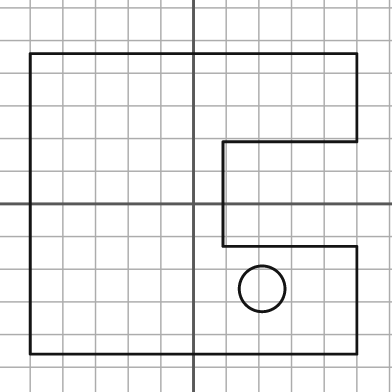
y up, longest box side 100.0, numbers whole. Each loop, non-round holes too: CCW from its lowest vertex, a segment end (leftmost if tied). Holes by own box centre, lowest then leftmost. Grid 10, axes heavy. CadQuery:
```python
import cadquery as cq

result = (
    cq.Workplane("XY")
    .moveTo(-50.0, -46.0)
    .lineTo(50.0, -46.0)
    .lineTo(50.0, -13.0)
    .lineTo(9.0, -13.0)
    .lineTo(9.0, 19.0)
    .lineTo(50.0, 19.0)
    .lineTo(50.0, 46.0)
    .lineTo(-50.0, 46.0)
    .close()
    .moveTo(21.0, -26.0)
    .circle(7.0)
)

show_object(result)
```